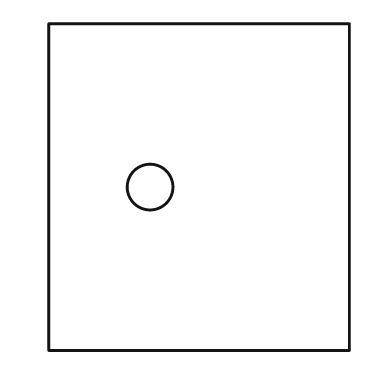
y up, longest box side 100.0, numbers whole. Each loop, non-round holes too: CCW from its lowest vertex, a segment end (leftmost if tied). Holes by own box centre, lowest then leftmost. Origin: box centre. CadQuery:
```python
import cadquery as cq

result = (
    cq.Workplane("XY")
    .moveTo(-46.0, -50.0)
    .lineTo(46.0, -50.0)
    .lineTo(46.0, 50.0)
    .lineTo(-46.0, 50.0)
    .close()
    .moveTo(-15.0, 0.0)
    .circle(7.0)
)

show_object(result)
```